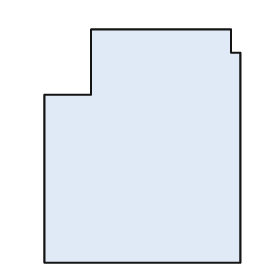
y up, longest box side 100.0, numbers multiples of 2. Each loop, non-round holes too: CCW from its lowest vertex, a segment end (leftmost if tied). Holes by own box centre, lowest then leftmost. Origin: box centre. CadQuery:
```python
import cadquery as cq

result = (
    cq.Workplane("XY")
    .moveTo(-42.0, -50.0)
    .lineTo(42.0, -50.0)
    .lineTo(42.0, 40.0)
    .lineTo(38.0, 40.0)
    .lineTo(38.0, 50.0)
    .lineTo(-22.0, 50.0)
    .lineTo(-22.0, 22.0)
    .lineTo(-42.0, 22.0)
    .close()
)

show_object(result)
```